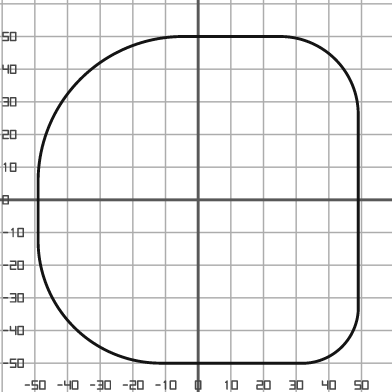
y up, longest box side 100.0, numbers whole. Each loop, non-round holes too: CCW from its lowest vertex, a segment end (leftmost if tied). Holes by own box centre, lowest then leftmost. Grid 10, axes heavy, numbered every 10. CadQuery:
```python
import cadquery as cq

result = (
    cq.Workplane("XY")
    .moveTo(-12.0, -50.0)
    .lineTo(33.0, -50.0)
    .threePointArc((44.0, -45.0), (49.0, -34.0))
    .lineTo(49.0, 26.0)
    .threePointArc((42.0, 43.0), (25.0, 50.0))
    .lineTo(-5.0, 50.0)
    .threePointArc((-36.0, 37.0), (-49.0, 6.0))
    .lineTo(-49.0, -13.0)
    .threePointArc((-38.0, -39.0), (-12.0, -50.0))
    .close()
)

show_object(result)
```